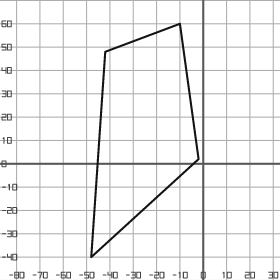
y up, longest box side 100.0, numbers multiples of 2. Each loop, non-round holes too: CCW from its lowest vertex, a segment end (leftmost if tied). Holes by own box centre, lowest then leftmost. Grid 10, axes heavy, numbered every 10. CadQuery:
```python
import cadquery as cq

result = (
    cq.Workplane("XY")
    .moveTo(-48.0, -40.0)
    .lineTo(-2.0, 2.0)
    .lineTo(-10.0, 60.0)
    .lineTo(-42.0, 48.0)
    .close()
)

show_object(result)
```